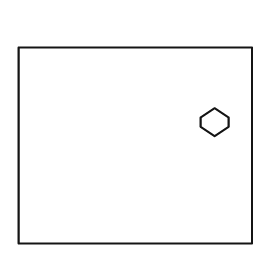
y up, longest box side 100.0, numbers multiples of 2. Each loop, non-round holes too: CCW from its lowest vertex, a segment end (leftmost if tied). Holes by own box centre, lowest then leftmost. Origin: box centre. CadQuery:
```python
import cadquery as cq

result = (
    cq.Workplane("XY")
    .moveTo(-50.0, -42.0)
    .lineTo(50.0, -42.0)
    .lineTo(50.0, 42.0)
    .lineTo(-50.0, 42.0)
    .close()
    .moveTo(34.0, 4.0)
    .lineTo(40.0, 8.0)
    .lineTo(40.0, 12.0)
    .lineTo(34.0, 16.0)
    .lineTo(28.0, 12.0)
    .lineTo(28.0, 8.0)
    .close()
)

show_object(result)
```